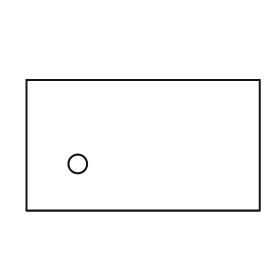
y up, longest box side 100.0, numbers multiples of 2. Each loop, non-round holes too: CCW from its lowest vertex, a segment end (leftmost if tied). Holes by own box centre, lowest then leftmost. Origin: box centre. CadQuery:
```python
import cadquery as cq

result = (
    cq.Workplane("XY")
    .moveTo(-50.0, -28.0)
    .lineTo(50.0, -28.0)
    .lineTo(50.0, 28.0)
    .lineTo(-50.0, 28.0)
    .close()
    .moveTo(-28.0, -8.0)
    .circle(4.0)
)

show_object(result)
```